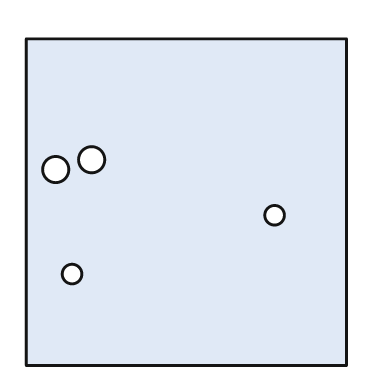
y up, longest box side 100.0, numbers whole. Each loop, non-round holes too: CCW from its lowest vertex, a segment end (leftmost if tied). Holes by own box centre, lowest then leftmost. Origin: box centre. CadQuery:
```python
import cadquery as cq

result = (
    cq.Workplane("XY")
    .moveTo(-49.0, -50.0)
    .lineTo(49.0, -50.0)
    .lineTo(49.0, 50.0)
    .lineTo(-49.0, 50.0)
    .close()
    .moveTo(-35.0, -22.0)
    .circle(3.0)
    .moveTo(27.0, -4.0)
    .circle(3.0)
    .moveTo(-40.0, 10.0)
    .circle(4.0)
    .moveTo(-29.0, 13.0)
    .circle(4.0)
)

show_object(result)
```